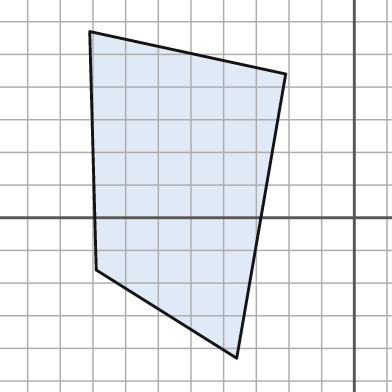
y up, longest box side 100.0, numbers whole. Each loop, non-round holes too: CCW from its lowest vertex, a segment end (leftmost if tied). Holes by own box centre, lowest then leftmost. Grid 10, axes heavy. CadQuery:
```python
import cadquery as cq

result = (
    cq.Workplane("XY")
    .moveTo(-36.0, -43.0)
    .lineTo(-21.0, 44.0)
    .lineTo(-81.0, 57.0)
    .lineTo(-79.0, -16.0)
    .close()
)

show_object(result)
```